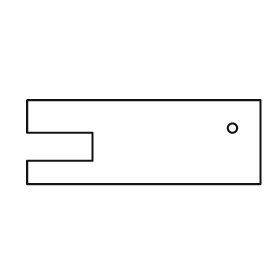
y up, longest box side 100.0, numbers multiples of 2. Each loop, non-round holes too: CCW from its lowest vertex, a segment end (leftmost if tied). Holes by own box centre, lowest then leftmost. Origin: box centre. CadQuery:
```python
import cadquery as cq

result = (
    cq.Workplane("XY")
    .moveTo(-50.0, -18.0)
    .lineTo(50.0, -18.0)
    .lineTo(50.0, 18.0)
    .lineTo(-50.0, 18.0)
    .lineTo(-50.0, 4.0)
    .lineTo(-22.0, 4.0)
    .lineTo(-22.0, -8.0)
    .lineTo(-50.0, -8.0)
    .close()
    .moveTo(38.0, 6.0)
    .circle(2.0)
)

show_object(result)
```